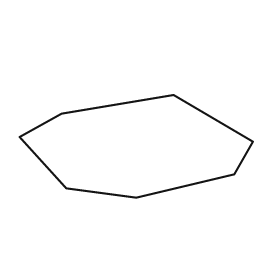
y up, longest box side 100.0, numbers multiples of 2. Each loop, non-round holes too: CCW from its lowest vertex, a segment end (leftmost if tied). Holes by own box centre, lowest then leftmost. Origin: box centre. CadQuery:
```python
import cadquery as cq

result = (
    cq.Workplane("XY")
    .moveTo(0.0, -22.0)
    .lineTo(42.0, -12.0)
    .lineTo(50.0, 2.0)
    .lineTo(16.0, 22.0)
    .lineTo(-32.0, 14.0)
    .lineTo(-50.0, 4.0)
    .lineTo(-30.0, -18.0)
    .close()
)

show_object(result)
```